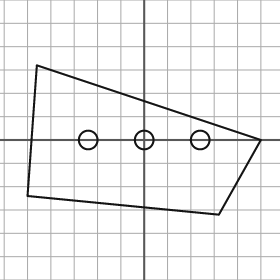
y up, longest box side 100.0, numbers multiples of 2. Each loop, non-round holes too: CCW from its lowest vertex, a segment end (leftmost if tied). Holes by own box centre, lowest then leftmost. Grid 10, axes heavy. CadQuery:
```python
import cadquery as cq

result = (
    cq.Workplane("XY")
    .moveTo(32.0, -32.0)
    .lineTo(50.0, 0.0)
    .lineTo(-46.0, 32.0)
    .lineTo(-50.0, -24.0)
    .close()
    .moveTo(-24.0, 0.0)
    .circle(4.0)
    .moveTo(0.0, 0.0)
    .circle(4.0)
    .moveTo(24.0, 0.0)
    .circle(4.0)
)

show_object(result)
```